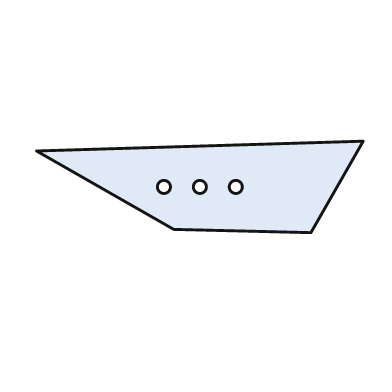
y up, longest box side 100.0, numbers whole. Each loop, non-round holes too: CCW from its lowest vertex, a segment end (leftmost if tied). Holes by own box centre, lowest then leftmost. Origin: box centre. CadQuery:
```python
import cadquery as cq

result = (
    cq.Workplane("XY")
    .moveTo(34.0, -14.0)
    .lineTo(50.0, 14.0)
    .lineTo(-50.0, 11.0)
    .lineTo(-8.0, -13.0)
    .close()
    .moveTo(-11.0, 0.0)
    .circle(2.0)
    .moveTo(0.0, 0.0)
    .circle(2.0)
    .moveTo(11.0, 0.0)
    .circle(2.0)
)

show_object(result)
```